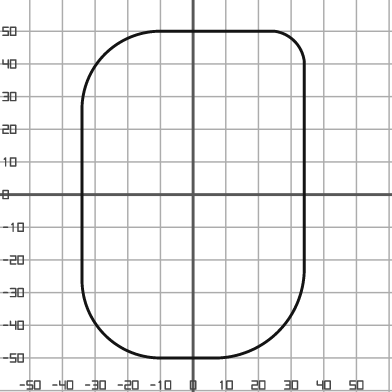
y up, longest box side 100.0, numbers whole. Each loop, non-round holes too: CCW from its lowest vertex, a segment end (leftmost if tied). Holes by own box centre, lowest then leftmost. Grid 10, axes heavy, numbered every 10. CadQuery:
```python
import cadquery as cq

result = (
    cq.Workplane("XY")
    .moveTo(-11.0, -50.0)
    .lineTo(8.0, -50.0)
    .threePointArc((26.0, -42.0), (34.0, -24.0))
    .lineTo(34.0, 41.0)
    .threePointArc((31.0, 47.0), (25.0, 50.0))
    .lineTo(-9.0, 50.0)
    .threePointArc((-27.0, 43.0), (-34.0, 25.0))
    .lineTo(-34.0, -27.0)
    .threePointArc((-27.0, -43.0), (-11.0, -50.0))
    .close()
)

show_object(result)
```